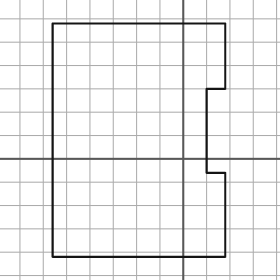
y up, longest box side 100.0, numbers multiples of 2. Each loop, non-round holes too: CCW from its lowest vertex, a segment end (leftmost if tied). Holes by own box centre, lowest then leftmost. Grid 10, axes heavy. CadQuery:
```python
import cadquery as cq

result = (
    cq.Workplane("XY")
    .moveTo(-56.0, -42.0)
    .lineTo(18.0, -42.0)
    .lineTo(18.0, -6.0)
    .lineTo(10.0, -6.0)
    .lineTo(10.0, 30.0)
    .lineTo(18.0, 30.0)
    .lineTo(18.0, 58.0)
    .lineTo(-56.0, 58.0)
    .close()
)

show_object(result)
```